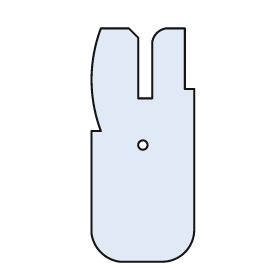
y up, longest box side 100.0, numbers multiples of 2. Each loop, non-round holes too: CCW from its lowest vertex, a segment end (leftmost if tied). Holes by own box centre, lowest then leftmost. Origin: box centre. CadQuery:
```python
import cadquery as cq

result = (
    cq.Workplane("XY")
    .moveTo(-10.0, -50.0)
    .lineTo(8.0, -50.0)
    .threePointArc((18.0, -46.0), (22.0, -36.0))
    .lineTo(22.0, 24.0)
    .lineTo(18.0, 24.0)
    .lineTo(18.0, 50.0)
    .lineTo(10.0, 50.0)
    .threePointArc((6.0, 48.0), (4.0, 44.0))
    .lineTo(4.0, 20.0)
    .lineTo(-2.0, 20.0)
    .lineTo(-2.0, 46.0)
    .lineTo(-6.0, 50.0)
    .lineTo(-18.0, 50.0)
    .threePointArc((-22.0, 28.0), (-18.0, 6.0))
    .lineTo(-22.0, 6.0)
    .lineTo(-22.0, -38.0)
    .threePointArc((-18.0, -46.0), (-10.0, -50.0))
    .close()
    .moveTo(0.0, 0.0)
    .circle(2.0)
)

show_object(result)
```